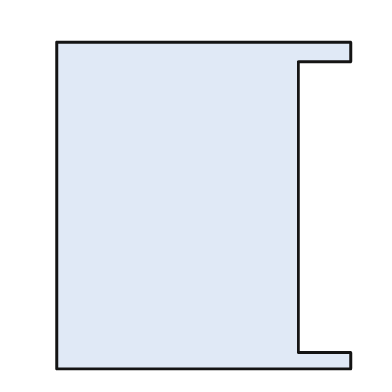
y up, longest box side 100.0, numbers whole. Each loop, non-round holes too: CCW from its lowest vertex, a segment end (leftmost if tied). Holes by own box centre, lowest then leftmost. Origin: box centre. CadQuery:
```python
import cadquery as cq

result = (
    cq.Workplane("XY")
    .moveTo(-45.0, -50.0)
    .lineTo(45.0, -50.0)
    .lineTo(45.0, -45.0)
    .lineTo(29.0, -45.0)
    .lineTo(29.0, 44.0)
    .lineTo(45.0, 44.0)
    .lineTo(45.0, 50.0)
    .lineTo(-45.0, 50.0)
    .close()
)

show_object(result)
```